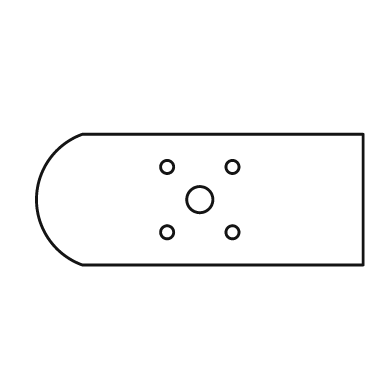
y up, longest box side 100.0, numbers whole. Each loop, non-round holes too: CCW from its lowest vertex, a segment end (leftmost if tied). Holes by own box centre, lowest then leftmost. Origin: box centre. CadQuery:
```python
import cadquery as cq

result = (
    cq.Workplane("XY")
    .moveTo(-36.0, -20.0)
    .lineTo(50.0, -20.0)
    .lineTo(50.0, 20.0)
    .lineTo(-36.0, 20.0)
    .threePointArc((-50.0, 0.0), (-36.0, -20.0))
    .close()
    .moveTo(-10.0, -10.0)
    .circle(2.0)
    .moveTo(10.0, -10.0)
    .circle(2.0)
    .moveTo(0.0, 0.0)
    .circle(4.0)
    .moveTo(-10.0, 10.0)
    .circle(2.0)
    .moveTo(10.0, 10.0)
    .circle(2.0)
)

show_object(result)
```